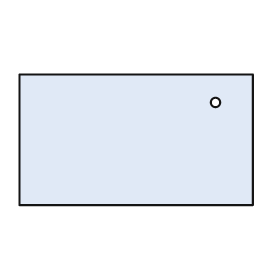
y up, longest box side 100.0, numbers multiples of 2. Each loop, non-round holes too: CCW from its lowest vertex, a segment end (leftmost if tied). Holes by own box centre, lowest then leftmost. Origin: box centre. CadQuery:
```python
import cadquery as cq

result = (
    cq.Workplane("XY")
    .moveTo(-50.0, -28.0)
    .lineTo(50.0, -28.0)
    .lineTo(50.0, 28.0)
    .lineTo(-50.0, 28.0)
    .close()
    .moveTo(34.0, 16.0)
    .circle(2.0)
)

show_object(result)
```